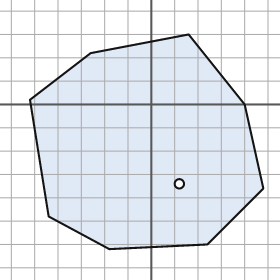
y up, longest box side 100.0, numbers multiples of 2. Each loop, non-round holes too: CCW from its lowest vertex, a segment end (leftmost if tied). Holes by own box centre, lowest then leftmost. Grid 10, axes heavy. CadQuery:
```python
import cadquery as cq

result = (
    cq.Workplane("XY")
    .moveTo(-18.0, -62.0)
    .lineTo(24.0, -60.0)
    .lineTo(48.0, -36.0)
    .lineTo(40.0, 0.0)
    .lineTo(16.0, 30.0)
    .lineTo(-26.0, 22.0)
    .lineTo(-52.0, 2.0)
    .lineTo(-44.0, -48.0)
    .close()
    .moveTo(12.0, -34.0)
    .circle(2.0)
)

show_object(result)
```